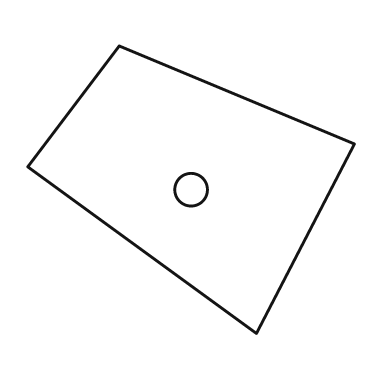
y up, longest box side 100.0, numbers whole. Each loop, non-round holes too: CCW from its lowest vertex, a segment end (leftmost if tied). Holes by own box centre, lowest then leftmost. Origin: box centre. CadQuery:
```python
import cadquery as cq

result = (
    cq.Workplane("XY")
    .moveTo(20.0, -44.0)
    .lineTo(50.0, 14.0)
    .lineTo(-22.0, 44.0)
    .lineTo(-50.0, 7.0)
    .close()
    .moveTo(0.0, 0.0)
    .circle(5.0)
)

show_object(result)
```